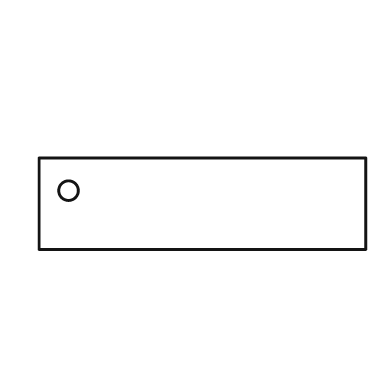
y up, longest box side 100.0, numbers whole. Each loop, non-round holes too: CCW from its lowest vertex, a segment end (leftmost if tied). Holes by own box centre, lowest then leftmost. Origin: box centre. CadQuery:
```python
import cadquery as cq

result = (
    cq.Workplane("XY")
    .moveTo(-50.0, -14.0)
    .lineTo(50.0, -14.0)
    .lineTo(50.0, 14.0)
    .lineTo(-50.0, 14.0)
    .close()
    .moveTo(-41.0, 4.0)
    .circle(3.0)
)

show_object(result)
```